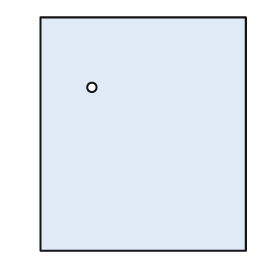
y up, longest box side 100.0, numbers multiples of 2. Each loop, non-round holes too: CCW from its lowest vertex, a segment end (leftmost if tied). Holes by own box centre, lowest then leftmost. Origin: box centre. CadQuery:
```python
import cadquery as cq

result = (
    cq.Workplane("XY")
    .moveTo(-44.0, -50.0)
    .lineTo(44.0, -50.0)
    .lineTo(44.0, 50.0)
    .lineTo(-44.0, 50.0)
    .close()
    .moveTo(-22.0, 20.0)
    .circle(2.0)
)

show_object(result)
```